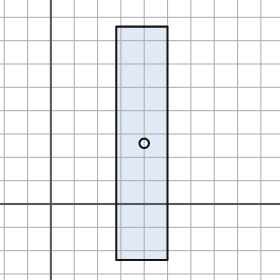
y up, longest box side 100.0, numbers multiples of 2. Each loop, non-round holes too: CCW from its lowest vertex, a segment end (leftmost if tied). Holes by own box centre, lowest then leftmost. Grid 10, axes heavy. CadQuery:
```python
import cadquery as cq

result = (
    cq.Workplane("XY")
    .moveTo(28.0, -24.0)
    .lineTo(50.0, -24.0)
    .lineTo(50.0, 76.0)
    .lineTo(28.0, 76.0)
    .close()
    .moveTo(40.0, 26.0)
    .circle(2.0)
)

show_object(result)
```